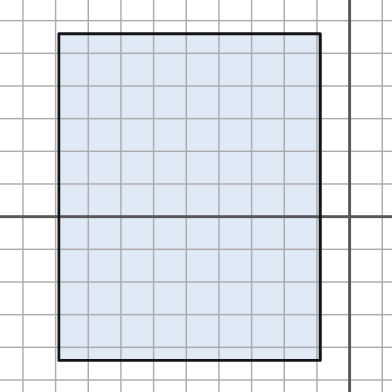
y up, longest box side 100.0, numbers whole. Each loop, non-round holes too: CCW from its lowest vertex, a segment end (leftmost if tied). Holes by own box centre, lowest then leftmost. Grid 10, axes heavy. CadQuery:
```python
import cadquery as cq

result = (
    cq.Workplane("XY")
    .moveTo(-89.0, -44.0)
    .lineTo(-9.0, -44.0)
    .lineTo(-9.0, 56.0)
    .lineTo(-89.0, 56.0)
    .close()
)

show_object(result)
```